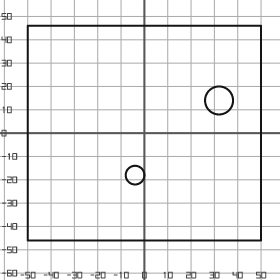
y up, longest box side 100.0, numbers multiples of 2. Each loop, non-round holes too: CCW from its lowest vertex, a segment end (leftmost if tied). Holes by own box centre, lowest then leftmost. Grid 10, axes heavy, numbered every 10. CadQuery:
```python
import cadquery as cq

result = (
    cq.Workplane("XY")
    .moveTo(-50.0, -46.0)
    .lineTo(50.0, -46.0)
    .lineTo(50.0, 46.0)
    .lineTo(-50.0, 46.0)
    .close()
    .moveTo(-4.0, -18.0)
    .circle(4.0)
    .moveTo(32.0, 14.0)
    .circle(6.0)
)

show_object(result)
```